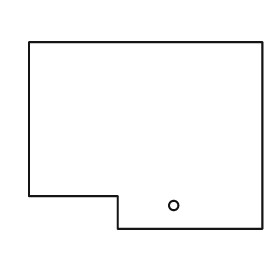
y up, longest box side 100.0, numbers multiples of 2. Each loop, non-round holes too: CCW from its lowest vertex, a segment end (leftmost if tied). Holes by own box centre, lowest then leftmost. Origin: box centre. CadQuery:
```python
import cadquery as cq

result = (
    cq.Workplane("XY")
    .moveTo(-12.0, -40.0)
    .lineTo(50.0, -40.0)
    .lineTo(50.0, 40.0)
    .lineTo(-50.0, 40.0)
    .lineTo(-50.0, -26.0)
    .lineTo(-12.0, -26.0)
    .close()
    .moveTo(12.0, -30.0)
    .circle(2.0)
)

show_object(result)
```